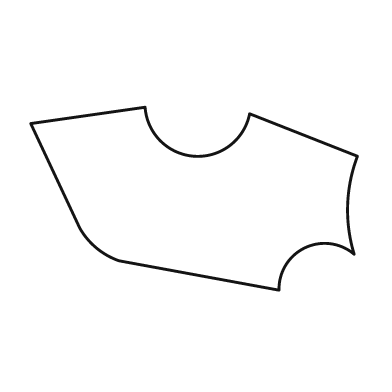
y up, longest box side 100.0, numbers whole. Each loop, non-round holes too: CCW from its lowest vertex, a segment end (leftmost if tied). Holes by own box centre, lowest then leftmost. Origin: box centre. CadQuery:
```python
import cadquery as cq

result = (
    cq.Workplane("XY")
    .moveTo(26.0, -28.0)
    .threePointArc((34.0, -15.0), (49.0, -17.0))
    .threePointArc((47.0, -2.0), (50.0, 13.0))
    .lineTo(17.0, 26.0)
    .threePointArc((0.0, 13.0), (-15.0, 28.0))
    .lineTo(-50.0, 23.0)
    .lineTo(-35.0, -9.0)
    .threePointArc((-30.0, -15.0), (-23.0, -19.0))
    .close()
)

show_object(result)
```